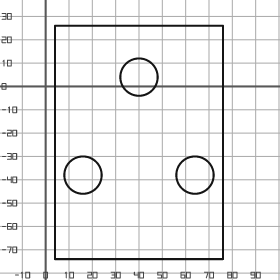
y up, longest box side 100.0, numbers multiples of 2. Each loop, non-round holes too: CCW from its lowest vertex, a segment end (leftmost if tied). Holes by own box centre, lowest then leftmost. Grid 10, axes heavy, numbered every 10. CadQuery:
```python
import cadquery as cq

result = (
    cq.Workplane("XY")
    .moveTo(4.0, -74.0)
    .lineTo(76.0, -74.0)
    .lineTo(76.0, 26.0)
    .lineTo(4.0, 26.0)
    .close()
    .moveTo(16.0, -38.0)
    .circle(8.0)
    .moveTo(64.0, -38.0)
    .circle(8.0)
    .moveTo(40.0, 4.0)
    .circle(8.0)
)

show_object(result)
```